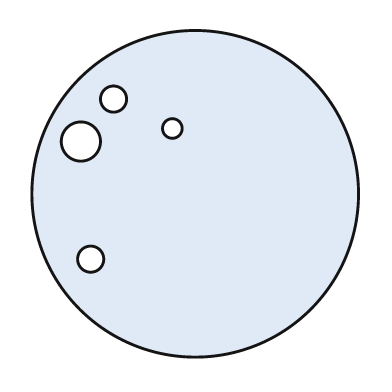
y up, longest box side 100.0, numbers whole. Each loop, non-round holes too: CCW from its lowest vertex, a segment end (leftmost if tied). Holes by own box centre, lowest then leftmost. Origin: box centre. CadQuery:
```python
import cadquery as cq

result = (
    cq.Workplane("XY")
    .moveTo(0.0, 0.0)
    .circle(50.0)
    .moveTo(-32.0, -20.0)
    .circle(4.0)
    .moveTo(-35.0, 16.0)
    .circle(6.0)
    .moveTo(-7.0, 20.0)
    .circle(3.0)
    .moveTo(-25.0, 29.0)
    .circle(4.0)
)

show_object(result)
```